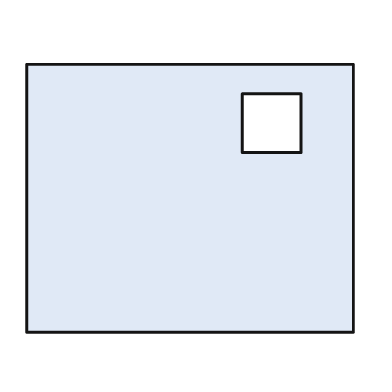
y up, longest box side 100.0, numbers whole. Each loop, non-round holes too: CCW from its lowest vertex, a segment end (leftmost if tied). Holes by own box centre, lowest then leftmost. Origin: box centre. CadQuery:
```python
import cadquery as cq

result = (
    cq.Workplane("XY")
    .moveTo(-50.0, -41.0)
    .lineTo(50.0, -41.0)
    .lineTo(50.0, 41.0)
    .lineTo(-50.0, 41.0)
    .close()
    .moveTo(16.0, 14.0)
    .lineTo(34.0, 14.0)
    .lineTo(34.0, 32.0)
    .lineTo(16.0, 32.0)
    .close()
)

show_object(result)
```